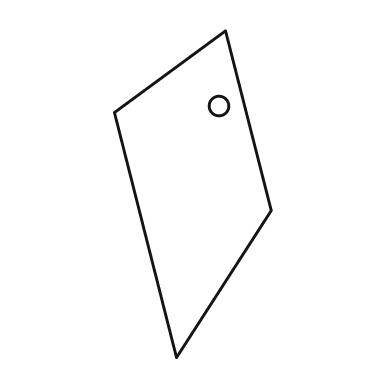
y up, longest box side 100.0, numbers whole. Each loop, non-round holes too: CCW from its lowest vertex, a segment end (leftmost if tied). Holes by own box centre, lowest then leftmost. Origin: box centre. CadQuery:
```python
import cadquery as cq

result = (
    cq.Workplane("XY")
    .moveTo(-5.0, -50.0)
    .lineTo(24.0, -5.0)
    .lineTo(10.0, 50.0)
    .lineTo(-24.0, 25.0)
    .close()
    .moveTo(8.0, 27.0)
    .circle(3.0)
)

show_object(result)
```